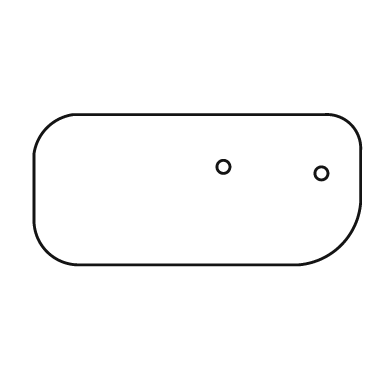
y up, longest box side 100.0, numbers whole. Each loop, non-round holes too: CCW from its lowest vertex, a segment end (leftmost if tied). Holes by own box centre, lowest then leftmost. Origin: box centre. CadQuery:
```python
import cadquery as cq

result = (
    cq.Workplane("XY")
    .moveTo(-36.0, -23.0)
    .lineTo(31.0, -23.0)
    .threePointArc((44.0, -17.0), (50.0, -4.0))
    .lineTo(50.0, 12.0)
    .threePointArc((47.0, 20.0), (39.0, 23.0))
    .lineTo(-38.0, 23.0)
    .threePointArc((-46.0, 19.0), (-50.0, 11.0))
    .lineTo(-50.0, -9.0)
    .threePointArc((-46.0, -19.0), (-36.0, -23.0))
    .close()
    .moveTo(38.0, 5.0)
    .circle(2.0)
    .moveTo(8.0, 7.0)
    .circle(2.0)
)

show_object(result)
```